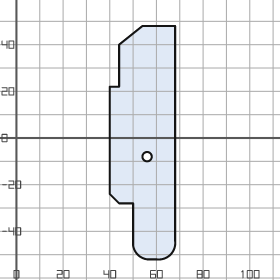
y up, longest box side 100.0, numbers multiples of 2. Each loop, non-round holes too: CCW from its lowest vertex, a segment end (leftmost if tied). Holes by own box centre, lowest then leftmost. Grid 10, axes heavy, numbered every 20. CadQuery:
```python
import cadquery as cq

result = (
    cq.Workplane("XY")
    .moveTo(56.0, -52.0)
    .lineTo(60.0, -52.0)
    .threePointArc((66.0, -50.0), (68.0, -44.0))
    .lineTo(68.0, 48.0)
    .lineTo(54.0, 48.0)
    .lineTo(44.0, 40.0)
    .lineTo(44.0, 22.0)
    .lineTo(40.0, 22.0)
    .lineTo(40.0, -24.0)
    .lineTo(44.0, -28.0)
    .lineTo(50.0, -28.0)
    .lineTo(50.0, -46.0)
    .threePointArc((52.0, -50.0), (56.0, -52.0))
    .close()
    .moveTo(56.0, -8.0)
    .circle(2.0)
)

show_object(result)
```